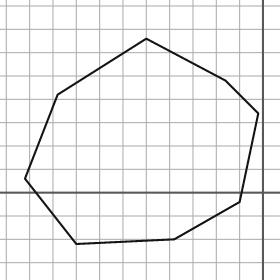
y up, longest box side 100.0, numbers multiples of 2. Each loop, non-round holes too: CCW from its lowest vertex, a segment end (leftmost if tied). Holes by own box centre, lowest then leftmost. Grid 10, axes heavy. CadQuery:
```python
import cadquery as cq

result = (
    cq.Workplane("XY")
    .moveTo(-80.0, -22.0)
    .lineTo(-38.0, -20.0)
    .lineTo(-10.0, -4.0)
    .lineTo(-2.0, 34.0)
    .lineTo(-16.0, 48.0)
    .lineTo(-50.0, 66.0)
    .lineTo(-88.0, 42.0)
    .lineTo(-102.0, 6.0)
    .close()
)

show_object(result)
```